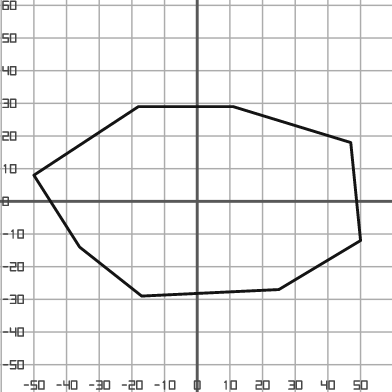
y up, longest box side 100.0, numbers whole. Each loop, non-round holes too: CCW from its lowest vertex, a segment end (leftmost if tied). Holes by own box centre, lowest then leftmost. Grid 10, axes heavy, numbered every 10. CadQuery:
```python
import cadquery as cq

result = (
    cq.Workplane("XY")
    .moveTo(-17.0, -29.0)
    .lineTo(25.0, -27.0)
    .lineTo(50.0, -12.0)
    .lineTo(47.0, 18.0)
    .lineTo(11.0, 29.0)
    .lineTo(-18.0, 29.0)
    .lineTo(-50.0, 8.0)
    .lineTo(-36.0, -14.0)
    .close()
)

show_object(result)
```